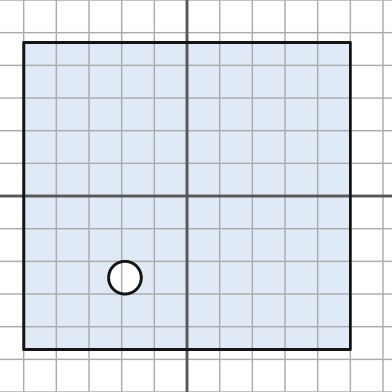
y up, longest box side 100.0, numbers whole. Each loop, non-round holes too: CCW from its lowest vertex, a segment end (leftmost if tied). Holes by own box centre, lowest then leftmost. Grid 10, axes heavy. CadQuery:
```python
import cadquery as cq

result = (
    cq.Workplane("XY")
    .moveTo(-50.0, -47.0)
    .lineTo(50.0, -47.0)
    .lineTo(50.0, 47.0)
    .lineTo(-50.0, 47.0)
    .close()
    .moveTo(-19.0, -25.0)
    .circle(5.0)
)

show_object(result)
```